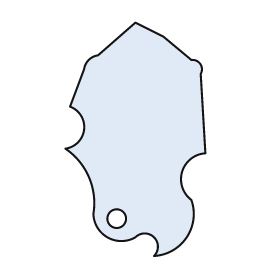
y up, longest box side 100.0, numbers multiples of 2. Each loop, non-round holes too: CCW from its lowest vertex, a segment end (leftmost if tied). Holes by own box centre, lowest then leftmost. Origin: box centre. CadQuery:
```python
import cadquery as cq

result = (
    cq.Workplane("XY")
    .moveTo(8.0, -50.0)
    .threePointArc((22.0, -42.0), (24.0, -26.0))
    .threePointArc((20.0, -14.0), (30.0, -6.0))
    .lineTo(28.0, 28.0)
    .threePointArc((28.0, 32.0), (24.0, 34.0))
    .lineTo(12.0, 44.0)
    .lineTo(0.0, 50.0)
    .lineTo(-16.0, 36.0)
    .threePointArc((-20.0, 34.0), (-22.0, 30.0))
    .lineTo(-28.0, 14.0)
    .threePointArc((-22.0, 4.0), (-30.0, -4.0))
    .threePointArc((-20.0, -16.0), (-18.0, -32.0))
    .threePointArc((-12.0, -42.0), (0.0, -42.0))
    .threePointArc((8.0, -42.0), (8.0, -50.0))
    .close()
    .moveTo(-8.0, -34.0)
    .circle(4.0)
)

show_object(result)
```